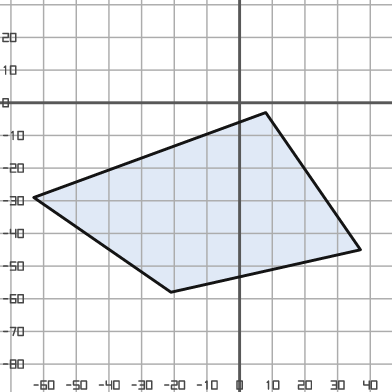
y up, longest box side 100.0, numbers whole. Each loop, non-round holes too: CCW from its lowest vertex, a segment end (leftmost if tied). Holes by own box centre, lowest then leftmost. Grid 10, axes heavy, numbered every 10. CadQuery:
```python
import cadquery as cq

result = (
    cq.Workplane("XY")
    .moveTo(-21.0, -58.0)
    .lineTo(37.0, -45.0)
    .lineTo(8.0, -3.0)
    .lineTo(-63.0, -29.0)
    .close()
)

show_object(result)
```